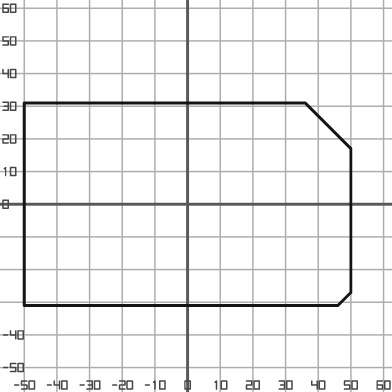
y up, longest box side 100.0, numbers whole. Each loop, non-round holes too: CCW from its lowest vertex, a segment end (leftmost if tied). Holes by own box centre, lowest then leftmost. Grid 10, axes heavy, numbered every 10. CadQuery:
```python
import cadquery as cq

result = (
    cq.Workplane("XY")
    .moveTo(-50.0, -31.0)
    .lineTo(46.0, -31.0)
    .lineTo(50.0, -27.0)
    .lineTo(50.0, 17.0)
    .lineTo(36.0, 31.0)
    .lineTo(-50.0, 31.0)
    .close()
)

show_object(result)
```